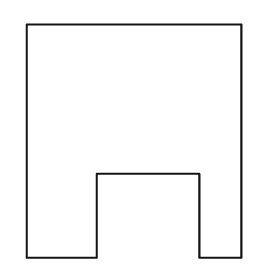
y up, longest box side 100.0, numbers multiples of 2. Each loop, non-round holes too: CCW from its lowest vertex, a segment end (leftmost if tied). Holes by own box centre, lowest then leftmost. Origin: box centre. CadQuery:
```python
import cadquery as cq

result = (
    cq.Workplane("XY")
    .moveTo(-46.0, -50.0)
    .lineTo(-16.0, -50.0)
    .lineTo(-16.0, -14.0)
    .lineTo(28.0, -14.0)
    .lineTo(28.0, -50.0)
    .lineTo(46.0, -50.0)
    .lineTo(46.0, 50.0)
    .lineTo(-46.0, 50.0)
    .close()
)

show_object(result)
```